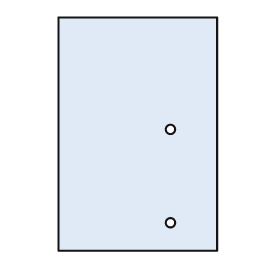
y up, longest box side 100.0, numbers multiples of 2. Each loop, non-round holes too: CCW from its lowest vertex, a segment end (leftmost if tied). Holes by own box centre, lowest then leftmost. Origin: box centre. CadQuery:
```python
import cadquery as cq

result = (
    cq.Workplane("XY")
    .moveTo(-34.0, -50.0)
    .lineTo(34.0, -50.0)
    .lineTo(34.0, 50.0)
    .lineTo(-34.0, 50.0)
    .close()
    .moveTo(14.0, -38.0)
    .circle(2.0)
    .moveTo(14.0, 2.0)
    .circle(2.0)
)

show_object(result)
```